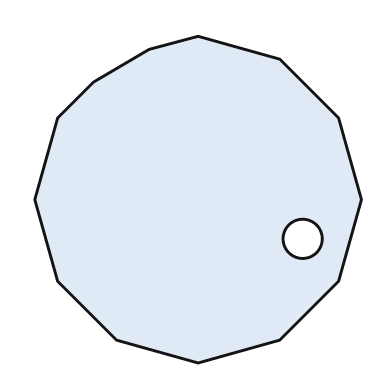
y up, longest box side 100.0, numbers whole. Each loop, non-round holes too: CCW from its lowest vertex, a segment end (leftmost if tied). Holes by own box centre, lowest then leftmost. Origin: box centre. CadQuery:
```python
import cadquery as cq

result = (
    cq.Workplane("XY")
    .moveTo(0.0, -50.0)
    .lineTo(25.0, -43.0)
    .lineTo(43.0, -25.0)
    .lineTo(50.0, 0.0)
    .lineTo(43.0, 25.0)
    .lineTo(25.0, 43.0)
    .lineTo(0.0, 50.0)
    .lineTo(-15.0, 46.0)
    .lineTo(-32.0, 36.0)
    .lineTo(-43.0, 25.0)
    .lineTo(-50.0, 0.0)
    .lineTo(-43.0, -25.0)
    .lineTo(-25.0, -43.0)
    .close()
    .moveTo(32.0, -12.0)
    .circle(6.0)
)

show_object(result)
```